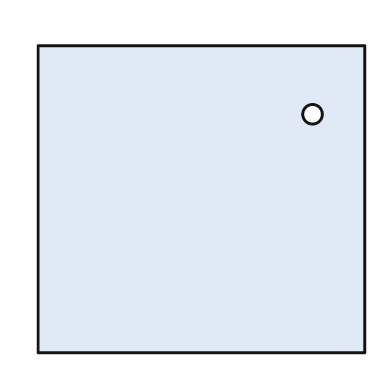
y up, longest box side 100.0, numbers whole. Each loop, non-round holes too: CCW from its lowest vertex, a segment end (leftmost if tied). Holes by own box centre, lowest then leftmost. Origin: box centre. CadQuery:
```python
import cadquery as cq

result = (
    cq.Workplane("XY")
    .moveTo(-50.0, -47.0)
    .lineTo(50.0, -47.0)
    .lineTo(50.0, 47.0)
    .lineTo(-50.0, 47.0)
    .close()
    .moveTo(34.0, 26.0)
    .circle(3.0)
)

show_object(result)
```